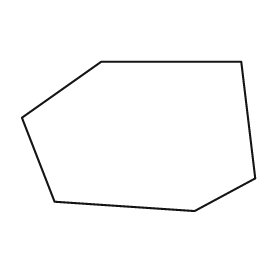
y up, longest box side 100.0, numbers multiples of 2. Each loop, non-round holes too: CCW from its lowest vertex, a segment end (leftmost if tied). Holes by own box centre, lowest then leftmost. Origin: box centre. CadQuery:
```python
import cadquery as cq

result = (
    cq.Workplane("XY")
    .moveTo(24.0, -32.0)
    .lineTo(50.0, -18.0)
    .lineTo(44.0, 32.0)
    .lineTo(-16.0, 32.0)
    .lineTo(-50.0, 8.0)
    .lineTo(-36.0, -28.0)
    .close()
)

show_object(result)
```